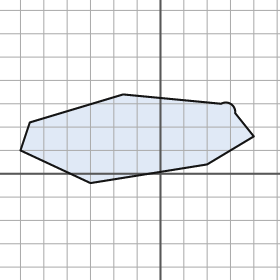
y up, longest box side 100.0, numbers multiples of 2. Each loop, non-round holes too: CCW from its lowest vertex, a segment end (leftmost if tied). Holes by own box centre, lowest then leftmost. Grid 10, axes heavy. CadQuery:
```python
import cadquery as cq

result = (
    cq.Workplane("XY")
    .moveTo(-30.0, -4.0)
    .lineTo(20.0, 4.0)
    .lineTo(40.0, 16.0)
    .lineTo(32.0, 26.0)
    .threePointArc((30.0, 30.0), (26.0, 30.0))
    .lineTo(-16.0, 34.0)
    .lineTo(-56.0, 22.0)
    .lineTo(-60.0, 10.0)
    .close()
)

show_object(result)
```